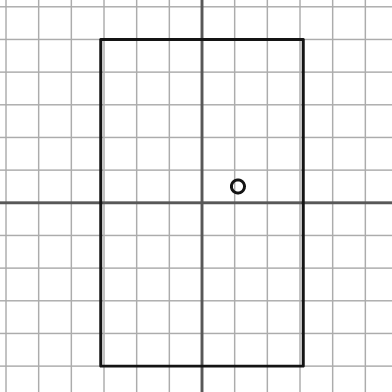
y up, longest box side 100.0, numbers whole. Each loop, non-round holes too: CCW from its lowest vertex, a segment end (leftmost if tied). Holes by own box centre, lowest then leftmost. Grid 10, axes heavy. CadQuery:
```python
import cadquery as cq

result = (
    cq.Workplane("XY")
    .moveTo(-31.0, -50.0)
    .lineTo(31.0, -50.0)
    .lineTo(31.0, 50.0)
    .lineTo(-31.0, 50.0)
    .close()
    .moveTo(11.0, 5.0)
    .circle(2.0)
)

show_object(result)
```